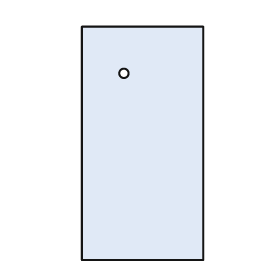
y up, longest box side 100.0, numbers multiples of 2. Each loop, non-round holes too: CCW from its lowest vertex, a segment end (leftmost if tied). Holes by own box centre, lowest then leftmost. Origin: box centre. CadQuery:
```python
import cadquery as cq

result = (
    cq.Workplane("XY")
    .moveTo(-26.0, -50.0)
    .lineTo(26.0, -50.0)
    .lineTo(26.0, 50.0)
    .lineTo(-26.0, 50.0)
    .close()
    .moveTo(-8.0, 30.0)
    .circle(2.0)
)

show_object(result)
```